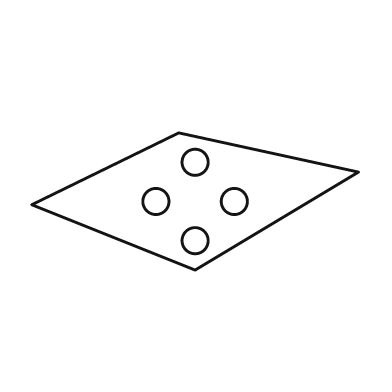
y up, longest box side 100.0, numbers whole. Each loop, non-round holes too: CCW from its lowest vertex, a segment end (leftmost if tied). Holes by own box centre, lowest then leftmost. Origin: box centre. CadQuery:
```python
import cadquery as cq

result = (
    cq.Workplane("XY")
    .moveTo(0.0, -21.0)
    .lineTo(50.0, 9.0)
    .lineTo(-5.0, 21.0)
    .lineTo(-50.0, -1.0)
    .close()
    .moveTo(0.0, -12.0)
    .circle(4.0)
    .moveTo(-12.0, 0.0)
    .circle(4.0)
    .moveTo(12.0, 0.0)
    .circle(4.0)
    .moveTo(0.0, 12.0)
    .circle(4.0)
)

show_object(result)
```